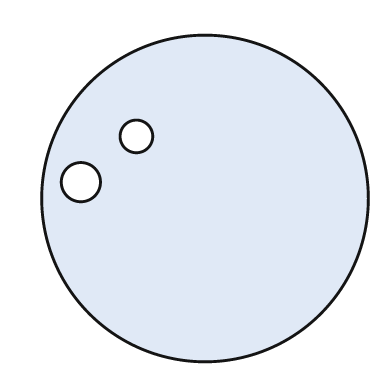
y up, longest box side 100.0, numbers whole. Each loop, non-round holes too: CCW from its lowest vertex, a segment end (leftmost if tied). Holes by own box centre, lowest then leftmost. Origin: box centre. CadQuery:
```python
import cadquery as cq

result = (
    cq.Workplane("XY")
    .moveTo(0.0, 0.0)
    .circle(50.0)
    .moveTo(-38.0, 5.0)
    .circle(6.0)
    .moveTo(-21.0, 19.0)
    .circle(5.0)
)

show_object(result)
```